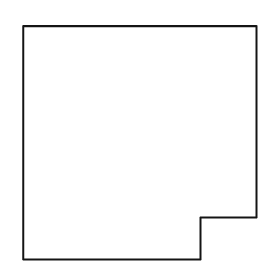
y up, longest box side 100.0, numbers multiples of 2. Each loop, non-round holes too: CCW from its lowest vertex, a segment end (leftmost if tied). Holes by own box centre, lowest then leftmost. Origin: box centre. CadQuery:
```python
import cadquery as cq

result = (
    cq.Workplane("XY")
    .moveTo(-50.0, -50.0)
    .lineTo(26.0, -50.0)
    .lineTo(26.0, -32.0)
    .lineTo(50.0, -32.0)
    .lineTo(50.0, 50.0)
    .lineTo(-50.0, 50.0)
    .close()
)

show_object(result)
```